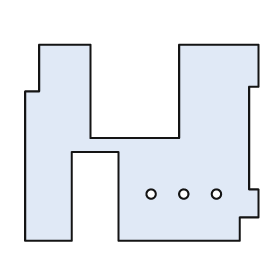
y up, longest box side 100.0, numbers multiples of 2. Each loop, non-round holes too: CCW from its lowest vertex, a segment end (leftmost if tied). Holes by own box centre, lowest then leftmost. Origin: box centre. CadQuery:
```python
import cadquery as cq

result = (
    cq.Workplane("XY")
    .moveTo(-50.0, -42.0)
    .lineTo(-30.0, -42.0)
    .lineTo(-30.0, -4.0)
    .lineTo(-10.0, -4.0)
    .lineTo(-10.0, -42.0)
    .lineTo(42.0, -42.0)
    .lineTo(42.0, -32.0)
    .lineTo(50.0, -32.0)
    .lineTo(50.0, -20.0)
    .lineTo(46.0, -20.0)
    .lineTo(46.0, 24.0)
    .lineTo(50.0, 24.0)
    .lineTo(50.0, 42.0)
    .lineTo(16.0, 42.0)
    .lineTo(16.0, 2.0)
    .lineTo(-22.0, 2.0)
    .lineTo(-22.0, 42.0)
    .lineTo(-44.0, 42.0)
    .lineTo(-44.0, 22.0)
    .lineTo(-50.0, 22.0)
    .close()
    .moveTo(4.0, -22.0)
    .circle(2.0)
    .moveTo(18.0, -22.0)
    .circle(2.0)
    .moveTo(32.0, -22.0)
    .circle(2.0)
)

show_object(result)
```